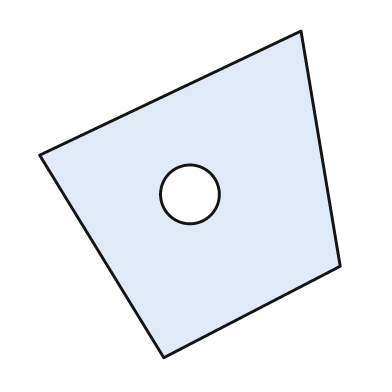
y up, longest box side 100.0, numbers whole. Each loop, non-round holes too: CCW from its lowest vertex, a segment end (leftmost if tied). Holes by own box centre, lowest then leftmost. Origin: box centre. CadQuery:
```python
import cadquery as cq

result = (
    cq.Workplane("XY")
    .moveTo(-8.0, -50.0)
    .lineTo(46.0, -22.0)
    .lineTo(34.0, 50.0)
    .lineTo(-46.0, 12.0)
    .close()
    .moveTo(0.0, 0.0)
    .circle(9.0)
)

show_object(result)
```